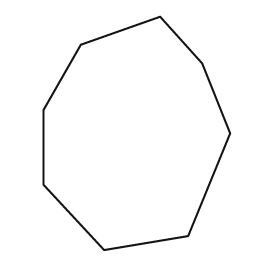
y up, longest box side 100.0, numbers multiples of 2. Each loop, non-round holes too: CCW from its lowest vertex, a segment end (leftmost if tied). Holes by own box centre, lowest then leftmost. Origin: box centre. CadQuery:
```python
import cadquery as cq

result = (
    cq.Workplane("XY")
    .moveTo(-14.0, -50.0)
    .lineTo(22.0, -44.0)
    .lineTo(40.0, 0.0)
    .lineTo(28.0, 30.0)
    .lineTo(10.0, 50.0)
    .lineTo(-24.0, 38.0)
    .lineTo(-40.0, 10.0)
    .lineTo(-40.0, -22.0)
    .close()
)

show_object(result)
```